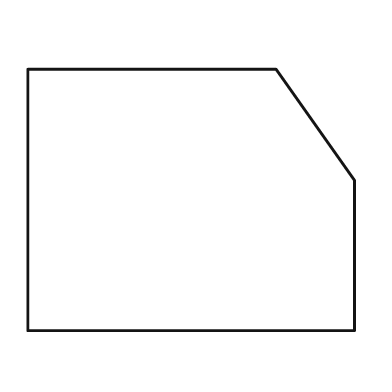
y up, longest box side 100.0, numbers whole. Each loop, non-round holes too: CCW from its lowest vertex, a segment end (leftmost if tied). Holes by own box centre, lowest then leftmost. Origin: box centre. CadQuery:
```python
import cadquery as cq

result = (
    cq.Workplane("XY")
    .moveTo(-50.0, -40.0)
    .lineTo(50.0, -40.0)
    .lineTo(50.0, 6.0)
    .lineTo(26.0, 40.0)
    .lineTo(-50.0, 40.0)
    .close()
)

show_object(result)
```